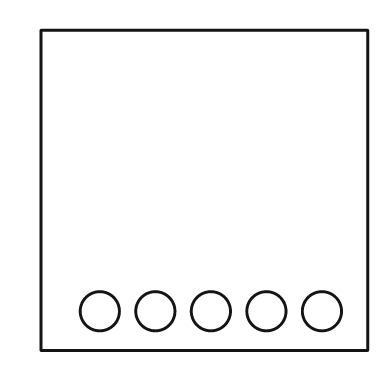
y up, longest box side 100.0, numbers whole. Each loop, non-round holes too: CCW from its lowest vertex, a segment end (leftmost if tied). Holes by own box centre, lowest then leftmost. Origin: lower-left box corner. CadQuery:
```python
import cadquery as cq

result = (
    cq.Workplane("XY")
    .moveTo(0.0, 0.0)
    .lineTo(100.0, 0.0)
    .lineTo(100.0, 98.0)
    .lineTo(0.0, 98.0)
    .close()
    .moveTo(18.0, 12.0)
    .circle(6.0)
    .moveTo(35.0, 12.0)
    .circle(6.0)
    .moveTo(52.0, 12.0)
    .circle(6.0)
    .moveTo(69.0, 12.0)
    .circle(6.0)
    .moveTo(86.0, 12.0)
    .circle(6.0)
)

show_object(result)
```